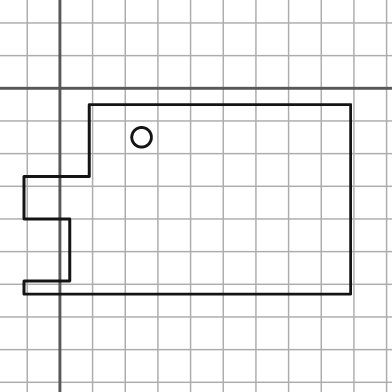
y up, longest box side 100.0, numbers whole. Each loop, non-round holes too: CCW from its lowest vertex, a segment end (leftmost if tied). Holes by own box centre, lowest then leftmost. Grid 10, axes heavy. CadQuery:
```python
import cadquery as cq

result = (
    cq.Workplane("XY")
    .moveTo(-11.0, -63.0)
    .lineTo(89.0, -63.0)
    .lineTo(89.0, -5.0)
    .lineTo(9.0, -5.0)
    .lineTo(9.0, -27.0)
    .lineTo(-11.0, -27.0)
    .lineTo(-11.0, -40.0)
    .lineTo(3.0, -40.0)
    .lineTo(3.0, -59.0)
    .lineTo(-11.0, -59.0)
    .close()
    .moveTo(25.0, -15.0)
    .circle(3.0)
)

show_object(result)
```